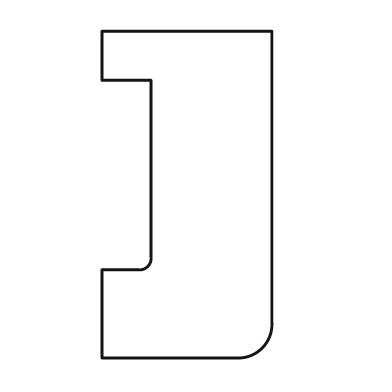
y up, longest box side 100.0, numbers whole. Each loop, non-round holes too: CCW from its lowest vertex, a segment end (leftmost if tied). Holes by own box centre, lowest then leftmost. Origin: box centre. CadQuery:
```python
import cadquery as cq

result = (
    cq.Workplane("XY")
    .moveTo(-26.0, -50.0)
    .lineTo(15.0, -50.0)
    .threePointArc((23.0, -47.0), (26.0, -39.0))
    .lineTo(26.0, 50.0)
    .lineTo(-26.0, 50.0)
    .lineTo(-26.0, 35.0)
    .lineTo(-11.0, 35.0)
    .lineTo(-11.0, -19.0)
    .threePointArc((-12.0, -22.0), (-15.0, -23.0))
    .lineTo(-26.0, -23.0)
    .close()
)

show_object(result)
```